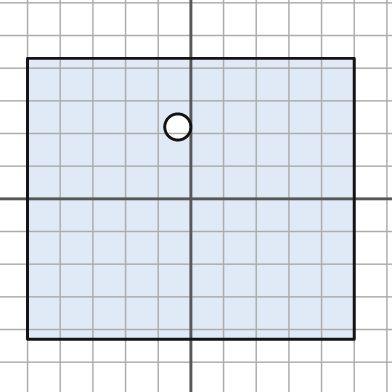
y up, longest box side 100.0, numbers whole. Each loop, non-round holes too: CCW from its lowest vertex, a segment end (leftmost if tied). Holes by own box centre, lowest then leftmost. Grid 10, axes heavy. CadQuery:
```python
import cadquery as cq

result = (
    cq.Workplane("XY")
    .moveTo(-50.0, -43.0)
    .lineTo(50.0, -43.0)
    .lineTo(50.0, 43.0)
    .lineTo(-50.0, 43.0)
    .close()
    .moveTo(-4.0, 22.0)
    .circle(4.0)
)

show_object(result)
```